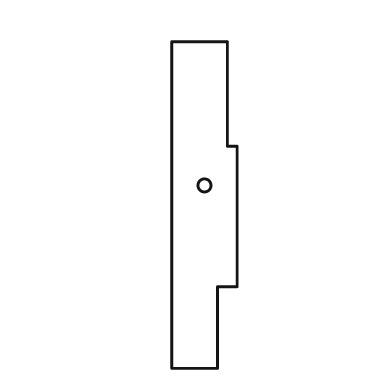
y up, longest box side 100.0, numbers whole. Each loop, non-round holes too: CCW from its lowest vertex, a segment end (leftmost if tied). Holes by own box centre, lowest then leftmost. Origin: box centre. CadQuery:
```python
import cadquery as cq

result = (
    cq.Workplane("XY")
    .moveTo(-10.0, -50.0)
    .lineTo(4.0, -50.0)
    .lineTo(4.0, -25.0)
    .lineTo(10.0, -25.0)
    .lineTo(10.0, 18.0)
    .lineTo(7.0, 18.0)
    .lineTo(7.0, 50.0)
    .lineTo(-10.0, 50.0)
    .close()
    .moveTo(0.0, 6.0)
    .circle(2.0)
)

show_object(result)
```